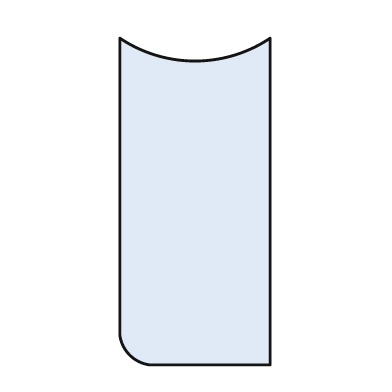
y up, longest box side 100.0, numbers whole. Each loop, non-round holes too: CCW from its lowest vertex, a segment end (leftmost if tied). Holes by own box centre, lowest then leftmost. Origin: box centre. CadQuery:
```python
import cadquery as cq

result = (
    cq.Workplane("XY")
    .moveTo(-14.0, -50.0)
    .lineTo(23.0, -50.0)
    .lineTo(23.0, 50.0)
    .threePointArc((0.0, 43.0), (-23.0, 50.0))
    .lineTo(-23.0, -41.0)
    .threePointArc((-20.0, -47.0), (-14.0, -50.0))
    .close()
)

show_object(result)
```